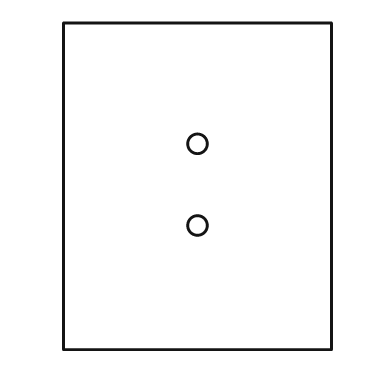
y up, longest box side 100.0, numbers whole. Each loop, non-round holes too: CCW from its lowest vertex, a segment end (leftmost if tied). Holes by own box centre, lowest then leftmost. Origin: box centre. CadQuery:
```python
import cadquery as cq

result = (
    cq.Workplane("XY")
    .moveTo(-41.0, -50.0)
    .lineTo(41.0, -50.0)
    .lineTo(41.0, 50.0)
    .lineTo(-41.0, 50.0)
    .close()
    .moveTo(0.0, -12.0)
    .circle(3.0)
    .moveTo(0.0, 13.0)
    .circle(3.0)
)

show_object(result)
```